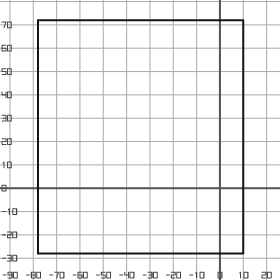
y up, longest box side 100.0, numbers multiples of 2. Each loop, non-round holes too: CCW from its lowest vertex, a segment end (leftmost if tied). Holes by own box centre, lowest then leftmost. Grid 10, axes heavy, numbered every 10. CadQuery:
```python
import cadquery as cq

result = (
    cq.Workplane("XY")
    .moveTo(-78.0, -28.0)
    .lineTo(10.0, -28.0)
    .lineTo(10.0, 72.0)
    .lineTo(-78.0, 72.0)
    .close()
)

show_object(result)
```